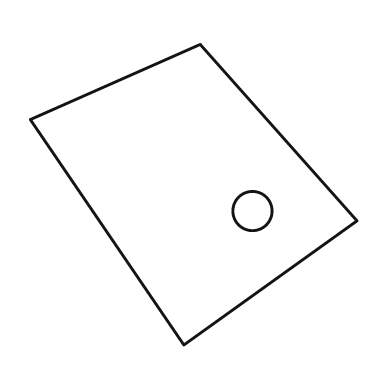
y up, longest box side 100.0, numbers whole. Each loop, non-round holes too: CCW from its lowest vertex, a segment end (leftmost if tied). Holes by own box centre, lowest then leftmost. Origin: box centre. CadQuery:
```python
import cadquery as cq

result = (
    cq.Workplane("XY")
    .moveTo(-3.0, -46.0)
    .lineTo(50.0, -8.0)
    .lineTo(2.0, 46.0)
    .lineTo(-50.0, 23.0)
    .close()
    .moveTo(18.0, -5.0)
    .circle(6.0)
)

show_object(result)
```